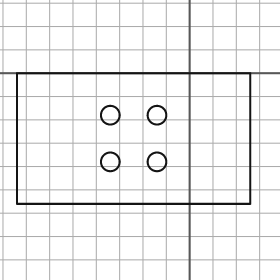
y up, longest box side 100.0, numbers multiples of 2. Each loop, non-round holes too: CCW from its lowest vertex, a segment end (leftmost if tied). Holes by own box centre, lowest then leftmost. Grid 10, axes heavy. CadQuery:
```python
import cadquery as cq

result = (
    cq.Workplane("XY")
    .moveTo(-74.0, -56.0)
    .lineTo(26.0, -56.0)
    .lineTo(26.0, 0.0)
    .lineTo(-74.0, 0.0)
    .close()
    .moveTo(-34.0, -38.0)
    .circle(4.0)
    .moveTo(-14.0, -38.0)
    .circle(4.0)
    .moveTo(-34.0, -18.0)
    .circle(4.0)
    .moveTo(-14.0, -18.0)
    .circle(4.0)
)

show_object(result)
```